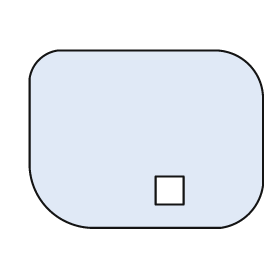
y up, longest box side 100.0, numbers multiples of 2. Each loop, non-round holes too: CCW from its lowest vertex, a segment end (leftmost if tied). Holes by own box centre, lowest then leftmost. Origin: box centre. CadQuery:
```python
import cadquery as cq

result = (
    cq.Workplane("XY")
    .moveTo(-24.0, -38.0)
    .lineTo(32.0, -38.0)
    .threePointArc((44.0, -32.0), (50.0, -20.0))
    .lineTo(50.0, 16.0)
    .threePointArc((44.0, 32.0), (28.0, 38.0))
    .lineTo(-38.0, 38.0)
    .threePointArc((-46.0, 34.0), (-50.0, 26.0))
    .lineTo(-50.0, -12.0)
    .threePointArc((-42.0, -30.0), (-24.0, -38.0))
    .close()
    .moveTo(4.0, -28.0)
    .lineTo(16.0, -28.0)
    .lineTo(16.0, -16.0)
    .lineTo(4.0, -16.0)
    .close()
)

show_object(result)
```